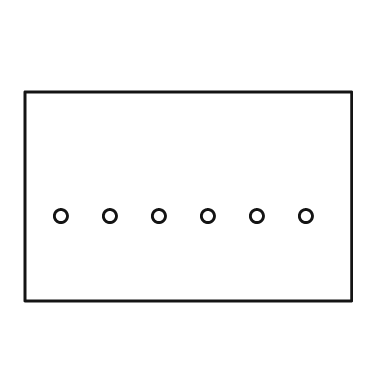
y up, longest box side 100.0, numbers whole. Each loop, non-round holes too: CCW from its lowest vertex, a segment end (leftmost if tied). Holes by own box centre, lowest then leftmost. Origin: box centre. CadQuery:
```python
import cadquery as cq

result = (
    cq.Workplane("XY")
    .moveTo(-50.0, -32.0)
    .lineTo(50.0, -32.0)
    .lineTo(50.0, 32.0)
    .lineTo(-50.0, 32.0)
    .close()
    .moveTo(-39.0, -6.0)
    .circle(2.0)
    .moveTo(-24.0, -6.0)
    .circle(2.0)
    .moveTo(-9.0, -6.0)
    .circle(2.0)
    .moveTo(6.0, -6.0)
    .circle(2.0)
    .moveTo(21.0, -6.0)
    .circle(2.0)
    .moveTo(36.0, -6.0)
    .circle(2.0)
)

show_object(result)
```